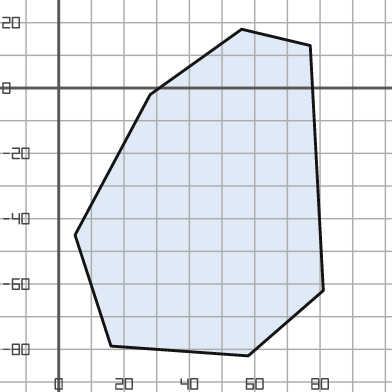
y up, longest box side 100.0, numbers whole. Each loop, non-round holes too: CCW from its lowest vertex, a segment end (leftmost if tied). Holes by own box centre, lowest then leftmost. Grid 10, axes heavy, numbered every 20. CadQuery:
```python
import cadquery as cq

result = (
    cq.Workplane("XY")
    .moveTo(58.0, -82.0)
    .lineTo(81.0, -62.0)
    .lineTo(77.0, 13.0)
    .lineTo(56.0, 18.0)
    .lineTo(28.0, -2.0)
    .lineTo(5.0, -45.0)
    .lineTo(16.0, -79.0)
    .close()
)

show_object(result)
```